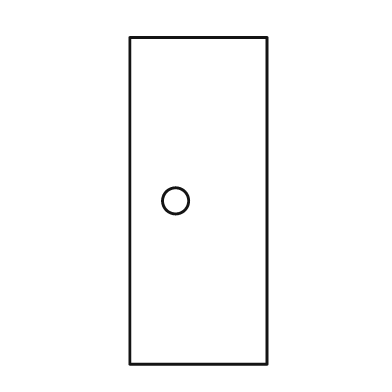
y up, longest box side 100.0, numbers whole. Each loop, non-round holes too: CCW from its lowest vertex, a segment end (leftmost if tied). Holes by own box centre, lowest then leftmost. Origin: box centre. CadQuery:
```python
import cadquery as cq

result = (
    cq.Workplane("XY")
    .moveTo(-21.0, -50.0)
    .lineTo(21.0, -50.0)
    .lineTo(21.0, 50.0)
    .lineTo(-21.0, 50.0)
    .close()
    .moveTo(-7.0, 0.0)
    .circle(4.0)
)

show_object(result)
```